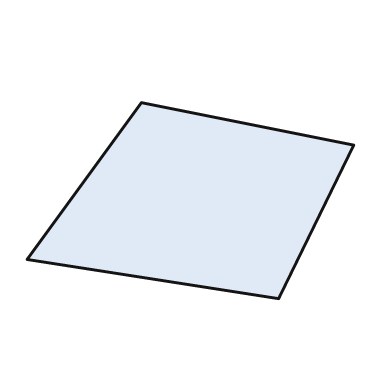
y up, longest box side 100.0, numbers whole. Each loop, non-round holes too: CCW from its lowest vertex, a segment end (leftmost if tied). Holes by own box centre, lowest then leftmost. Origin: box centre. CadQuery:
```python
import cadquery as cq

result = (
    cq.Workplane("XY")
    .moveTo(27.0, -30.0)
    .lineTo(50.0, 17.0)
    .lineTo(-15.0, 30.0)
    .lineTo(-50.0, -18.0)
    .close()
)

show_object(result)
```